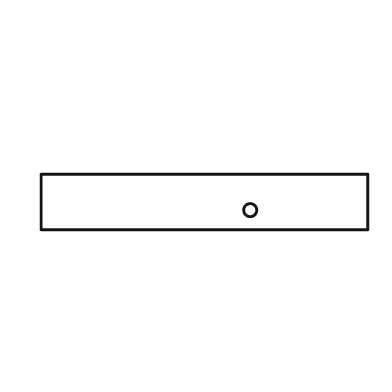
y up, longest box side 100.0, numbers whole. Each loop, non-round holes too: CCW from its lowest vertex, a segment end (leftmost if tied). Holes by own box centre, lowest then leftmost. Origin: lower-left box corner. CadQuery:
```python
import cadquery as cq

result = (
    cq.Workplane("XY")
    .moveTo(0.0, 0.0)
    .lineTo(100.0, 0.0)
    .lineTo(100.0, 17.0)
    .lineTo(0.0, 17.0)
    .close()
    .moveTo(64.0, 6.0)
    .circle(2.0)
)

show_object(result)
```